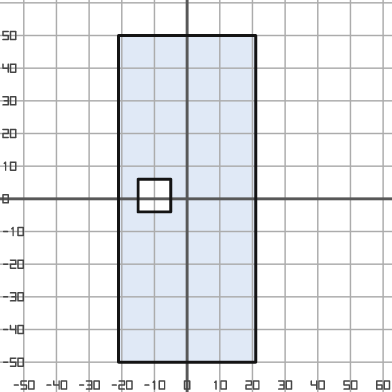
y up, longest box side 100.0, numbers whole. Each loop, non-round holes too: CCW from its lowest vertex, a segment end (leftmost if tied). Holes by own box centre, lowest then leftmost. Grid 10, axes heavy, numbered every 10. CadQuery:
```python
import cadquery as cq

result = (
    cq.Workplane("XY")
    .moveTo(-21.0, -50.0)
    .lineTo(21.0, -50.0)
    .lineTo(21.0, 50.0)
    .lineTo(-21.0, 50.0)
    .close()
    .moveTo(-15.0, -4.0)
    .lineTo(-5.0, -4.0)
    .lineTo(-5.0, 6.0)
    .lineTo(-15.0, 6.0)
    .close()
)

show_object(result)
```